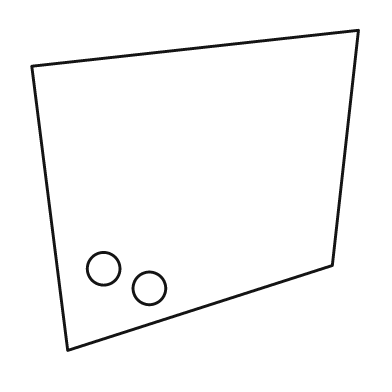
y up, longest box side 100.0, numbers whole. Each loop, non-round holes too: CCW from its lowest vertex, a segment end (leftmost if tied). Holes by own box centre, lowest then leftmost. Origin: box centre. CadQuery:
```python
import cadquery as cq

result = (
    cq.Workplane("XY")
    .moveTo(-39.0, -49.0)
    .lineTo(42.0, -23.0)
    .lineTo(50.0, 49.0)
    .lineTo(-50.0, 38.0)
    .close()
    .moveTo(-14.0, -30.0)
    .circle(5.0)
    .moveTo(-28.0, -24.0)
    .circle(5.0)
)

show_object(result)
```